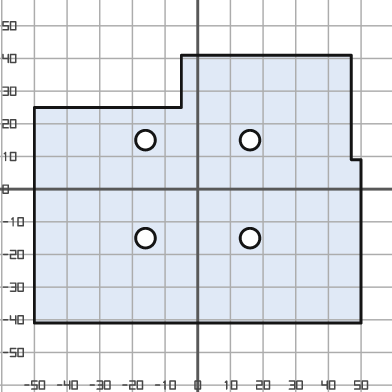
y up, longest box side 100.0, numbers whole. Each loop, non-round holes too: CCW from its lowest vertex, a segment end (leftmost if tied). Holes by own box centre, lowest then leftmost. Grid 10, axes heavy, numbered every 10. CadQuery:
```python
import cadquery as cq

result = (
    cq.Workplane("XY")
    .moveTo(-50.0, -41.0)
    .lineTo(50.0, -41.0)
    .lineTo(50.0, 9.0)
    .lineTo(47.0, 9.0)
    .lineTo(47.0, 41.0)
    .lineTo(-5.0, 41.0)
    .lineTo(-5.0, 25.0)
    .lineTo(-50.0, 25.0)
    .close()
    .moveTo(-16.0, -15.0)
    .circle(3.0)
    .moveTo(16.0, -15.0)
    .circle(3.0)
    .moveTo(-16.0, 15.0)
    .circle(3.0)
    .moveTo(16.0, 15.0)
    .circle(3.0)
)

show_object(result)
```